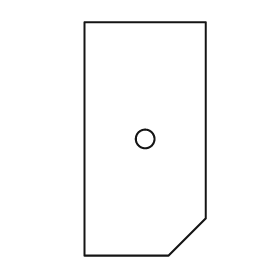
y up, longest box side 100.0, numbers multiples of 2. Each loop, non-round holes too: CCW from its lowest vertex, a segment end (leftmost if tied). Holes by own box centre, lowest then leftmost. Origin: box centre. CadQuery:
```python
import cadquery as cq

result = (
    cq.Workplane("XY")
    .moveTo(-26.0, -50.0)
    .lineTo(10.0, -50.0)
    .lineTo(26.0, -34.0)
    .lineTo(26.0, 50.0)
    .lineTo(-26.0, 50.0)
    .close()
    .moveTo(0.0, 0.0)
    .circle(4.0)
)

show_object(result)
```